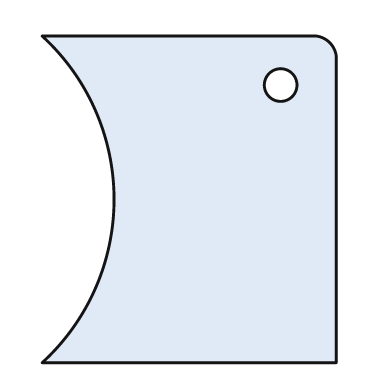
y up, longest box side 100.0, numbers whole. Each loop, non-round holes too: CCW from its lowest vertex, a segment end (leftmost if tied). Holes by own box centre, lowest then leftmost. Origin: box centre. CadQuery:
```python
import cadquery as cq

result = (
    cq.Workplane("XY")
    .moveTo(-45.0, -50.0)
    .lineTo(45.0, -50.0)
    .lineTo(45.0, 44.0)
    .threePointArc((43.0, 48.0), (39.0, 50.0))
    .lineTo(-45.0, 50.0)
    .threePointArc((-23.0, 0.0), (-45.0, -50.0))
    .close()
    .moveTo(28.0, 35.0)
    .circle(5.0)
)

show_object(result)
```